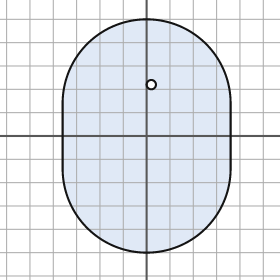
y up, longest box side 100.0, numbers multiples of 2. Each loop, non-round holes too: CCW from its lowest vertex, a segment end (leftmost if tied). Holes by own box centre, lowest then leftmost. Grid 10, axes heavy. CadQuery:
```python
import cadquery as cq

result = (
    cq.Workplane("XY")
    .moveTo(-36.0, -14.0)
    .threePointArc((0.0, -50.0), (36.0, -14.0))
    .lineTo(36.0, 14.0)
    .threePointArc((0.0, 50.0), (-36.0, 14.0))
    .close()
    .moveTo(2.0, 22.0)
    .circle(2.0)
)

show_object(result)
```